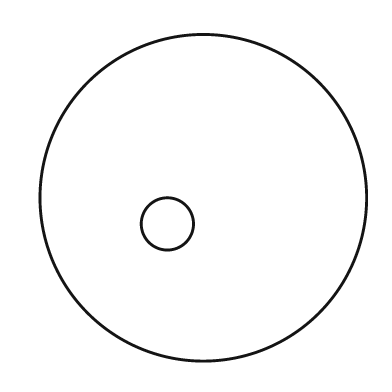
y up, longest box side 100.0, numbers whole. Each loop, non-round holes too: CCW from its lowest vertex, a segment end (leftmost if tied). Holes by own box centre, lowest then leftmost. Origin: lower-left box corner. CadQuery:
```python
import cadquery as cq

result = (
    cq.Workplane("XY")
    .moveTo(50.0, 50.0)
    .circle(50.0)
    .moveTo(39.0, 42.0)
    .circle(8.0)
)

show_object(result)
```